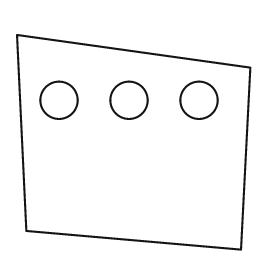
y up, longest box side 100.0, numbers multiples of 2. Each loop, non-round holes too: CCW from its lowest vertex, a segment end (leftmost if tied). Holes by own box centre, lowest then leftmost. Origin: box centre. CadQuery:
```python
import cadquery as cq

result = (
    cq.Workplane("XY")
    .moveTo(46.0, -46.0)
    .lineTo(50.0, 32.0)
    .lineTo(-50.0, 46.0)
    .lineTo(-46.0, -38.0)
    .close()
    .moveTo(-32.0, 18.0)
    .circle(8.0)
    .moveTo(-2.0, 18.0)
    .circle(8.0)
    .moveTo(28.0, 18.0)
    .circle(8.0)
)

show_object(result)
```